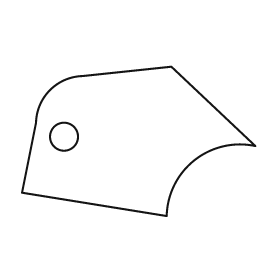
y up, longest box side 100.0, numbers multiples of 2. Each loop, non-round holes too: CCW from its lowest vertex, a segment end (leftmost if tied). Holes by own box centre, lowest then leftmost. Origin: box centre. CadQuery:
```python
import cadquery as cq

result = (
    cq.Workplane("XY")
    .moveTo(12.0, -32.0)
    .threePointArc((24.0, -8.0), (50.0, -2.0))
    .lineTo(14.0, 32.0)
    .lineTo(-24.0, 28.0)
    .threePointArc((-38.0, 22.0), (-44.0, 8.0))
    .lineTo(-50.0, -22.0)
    .close()
    .moveTo(-32.0, 2.0)
    .circle(6.0)
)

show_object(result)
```